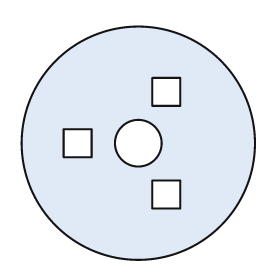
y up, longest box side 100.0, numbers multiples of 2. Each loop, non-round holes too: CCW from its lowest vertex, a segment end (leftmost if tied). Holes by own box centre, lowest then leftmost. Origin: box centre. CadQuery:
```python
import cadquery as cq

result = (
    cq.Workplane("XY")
    .moveTo(0.0, 0.0)
    .circle(50.0)
    .moveTo(6.0, -28.0)
    .lineTo(18.0, -28.0)
    .lineTo(18.0, -16.0)
    .lineTo(6.0, -16.0)
    .close()
    .moveTo(-32.0, -6.0)
    .lineTo(-20.0, -6.0)
    .lineTo(-20.0, 6.0)
    .lineTo(-32.0, 6.0)
    .close()
    .moveTo(0.0, 0.0)
    .circle(10.0)
    .moveTo(6.0, 16.0)
    .lineTo(18.0, 16.0)
    .lineTo(18.0, 28.0)
    .lineTo(6.0, 28.0)
    .close()
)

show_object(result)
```